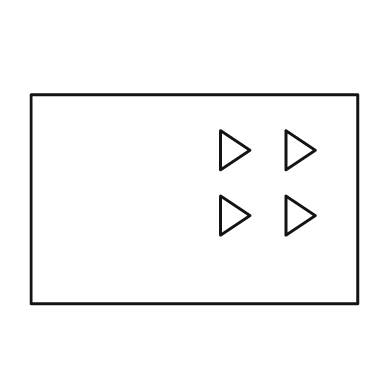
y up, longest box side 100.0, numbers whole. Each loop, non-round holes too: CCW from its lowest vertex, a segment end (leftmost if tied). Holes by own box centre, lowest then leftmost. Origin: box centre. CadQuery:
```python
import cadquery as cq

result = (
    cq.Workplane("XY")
    .moveTo(-50.0, -32.0)
    .lineTo(50.0, -32.0)
    .lineTo(50.0, 32.0)
    .lineTo(-50.0, 32.0)
    .close()
    .moveTo(8.0, -11.0)
    .lineTo(17.0, -5.0)
    .lineTo(8.0, 1.0)
    .close()
    .moveTo(28.0, -11.0)
    .lineTo(37.0, -5.0)
    .lineTo(28.0, 1.0)
    .close()
    .moveTo(8.0, 9.0)
    .lineTo(17.0, 15.0)
    .lineTo(8.0, 21.0)
    .close()
    .moveTo(28.0, 9.0)
    .lineTo(37.0, 15.0)
    .lineTo(28.0, 21.0)
    .close()
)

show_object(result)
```